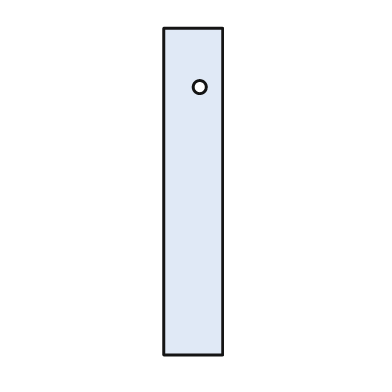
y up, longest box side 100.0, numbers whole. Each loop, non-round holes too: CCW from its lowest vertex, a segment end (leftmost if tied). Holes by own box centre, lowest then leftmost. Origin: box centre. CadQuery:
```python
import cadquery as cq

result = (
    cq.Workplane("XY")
    .moveTo(-9.0, -50.0)
    .lineTo(9.0, -50.0)
    .lineTo(9.0, 50.0)
    .lineTo(-9.0, 50.0)
    .close()
    .moveTo(2.0, 32.0)
    .circle(2.0)
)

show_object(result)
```